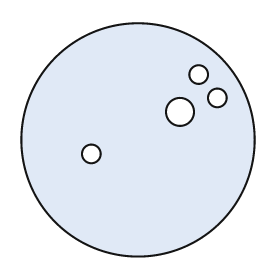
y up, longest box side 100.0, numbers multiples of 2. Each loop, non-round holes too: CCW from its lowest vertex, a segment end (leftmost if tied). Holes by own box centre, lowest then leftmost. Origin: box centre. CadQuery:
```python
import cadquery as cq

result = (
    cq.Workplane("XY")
    .moveTo(0.0, 0.0)
    .circle(50.0)
    .moveTo(-20.0, -6.0)
    .circle(4.0)
    .moveTo(18.0, 12.0)
    .circle(6.0)
    .moveTo(34.0, 18.0)
    .circle(4.0)
    .moveTo(26.0, 28.0)
    .circle(4.0)
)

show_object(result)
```